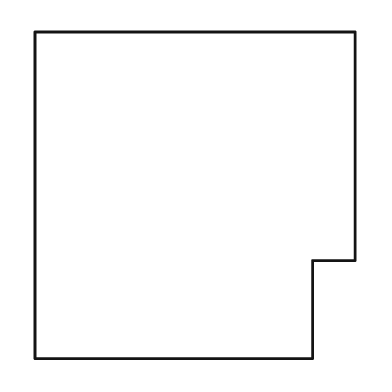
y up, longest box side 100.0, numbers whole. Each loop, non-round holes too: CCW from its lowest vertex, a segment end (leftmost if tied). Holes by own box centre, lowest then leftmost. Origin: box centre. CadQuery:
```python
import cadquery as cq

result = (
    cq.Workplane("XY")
    .moveTo(-49.0, -50.0)
    .lineTo(36.0, -50.0)
    .lineTo(36.0, -20.0)
    .lineTo(49.0, -20.0)
    .lineTo(49.0, 50.0)
    .lineTo(-49.0, 50.0)
    .close()
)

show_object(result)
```